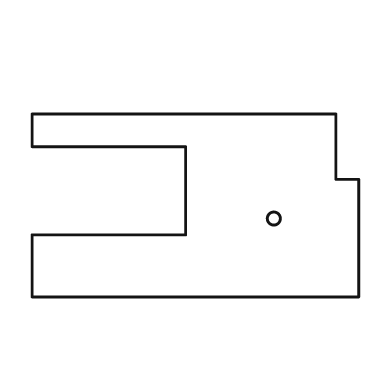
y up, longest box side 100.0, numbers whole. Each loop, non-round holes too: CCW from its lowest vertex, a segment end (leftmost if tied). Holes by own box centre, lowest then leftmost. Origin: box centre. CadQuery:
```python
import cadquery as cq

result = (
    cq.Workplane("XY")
    .moveTo(-50.0, -28.0)
    .lineTo(50.0, -28.0)
    .lineTo(50.0, 8.0)
    .lineTo(43.0, 8.0)
    .lineTo(43.0, 28.0)
    .lineTo(-50.0, 28.0)
    .lineTo(-50.0, 18.0)
    .lineTo(-3.0, 18.0)
    .lineTo(-3.0, -9.0)
    .lineTo(-50.0, -9.0)
    .close()
    .moveTo(24.0, -4.0)
    .circle(2.0)
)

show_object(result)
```